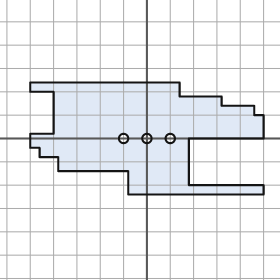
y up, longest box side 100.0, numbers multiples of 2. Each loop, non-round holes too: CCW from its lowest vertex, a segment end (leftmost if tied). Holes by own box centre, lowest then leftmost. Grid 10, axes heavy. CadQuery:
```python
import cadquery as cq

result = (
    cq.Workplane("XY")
    .moveTo(-8.0, -24.0)
    .lineTo(50.0, -24.0)
    .lineTo(50.0, -20.0)
    .lineTo(18.0, -20.0)
    .lineTo(18.0, 0.0)
    .lineTo(50.0, 0.0)
    .lineTo(50.0, 10.0)
    .lineTo(46.0, 10.0)
    .lineTo(46.0, 14.0)
    .lineTo(32.0, 14.0)
    .lineTo(32.0, 18.0)
    .lineTo(14.0, 18.0)
    .lineTo(14.0, 24.0)
    .lineTo(-50.0, 24.0)
    .lineTo(-50.0, 20.0)
    .lineTo(-40.0, 20.0)
    .lineTo(-40.0, 2.0)
    .lineTo(-50.0, 2.0)
    .lineTo(-50.0, -4.0)
    .lineTo(-46.0, -4.0)
    .lineTo(-46.0, -8.0)
    .lineTo(-38.0, -8.0)
    .lineTo(-38.0, -14.0)
    .lineTo(-8.0, -14.0)
    .close()
    .moveTo(-10.0, 0.0)
    .circle(2.0)
    .moveTo(0.0, 0.0)
    .circle(2.0)
    .moveTo(10.0, 0.0)
    .circle(2.0)
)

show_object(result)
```